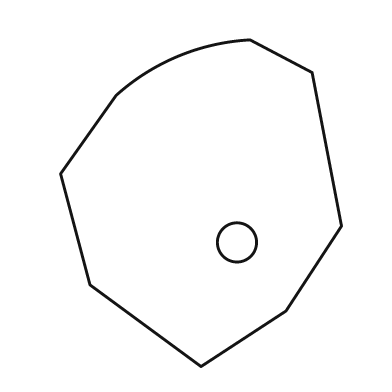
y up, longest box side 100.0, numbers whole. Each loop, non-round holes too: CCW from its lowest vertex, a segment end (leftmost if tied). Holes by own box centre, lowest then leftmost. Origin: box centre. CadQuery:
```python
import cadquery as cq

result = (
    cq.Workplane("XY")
    .moveTo(0.0, -50.0)
    .lineTo(26.0, -33.0)
    .lineTo(43.0, -7.0)
    .lineTo(34.0, 40.0)
    .lineTo(15.0, 50.0)
    .threePointArc((-7.0, 45.0), (-26.0, 33.0))
    .lineTo(-43.0, 9.0)
    .lineTo(-34.0, -25.0)
    .close()
    .moveTo(11.0, -12.0)
    .circle(6.0)
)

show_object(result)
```